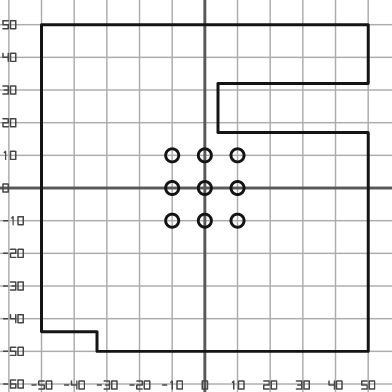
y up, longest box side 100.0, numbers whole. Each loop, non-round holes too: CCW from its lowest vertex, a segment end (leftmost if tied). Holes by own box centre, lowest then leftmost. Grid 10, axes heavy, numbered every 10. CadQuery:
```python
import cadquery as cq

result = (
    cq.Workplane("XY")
    .moveTo(-33.0, -50.0)
    .lineTo(50.0, -50.0)
    .lineTo(50.0, 17.0)
    .lineTo(4.0, 17.0)
    .lineTo(4.0, 32.0)
    .lineTo(50.0, 32.0)
    .lineTo(50.0, 50.0)
    .lineTo(-50.0, 50.0)
    .lineTo(-50.0, -44.0)
    .lineTo(-33.0, -44.0)
    .close()
    .moveTo(-10.0, -10.0)
    .circle(2.0)
    .moveTo(0.0, -10.0)
    .circle(2.0)
    .moveTo(10.0, -10.0)
    .circle(2.0)
    .moveTo(-10.0, 0.0)
    .circle(2.0)
    .moveTo(0.0, 0.0)
    .circle(2.0)
    .moveTo(10.0, 0.0)
    .circle(2.0)
    .moveTo(-10.0, 10.0)
    .circle(2.0)
    .moveTo(0.0, 10.0)
    .circle(2.0)
    .moveTo(10.0, 10.0)
    .circle(2.0)
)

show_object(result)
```